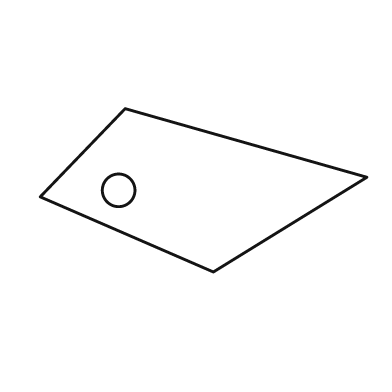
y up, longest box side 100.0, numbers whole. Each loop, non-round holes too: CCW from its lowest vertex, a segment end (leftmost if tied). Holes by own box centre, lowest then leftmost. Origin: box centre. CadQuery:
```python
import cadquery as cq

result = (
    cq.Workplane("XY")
    .moveTo(3.0, -25.0)
    .lineTo(50.0, 4.0)
    .lineTo(-24.0, 25.0)
    .lineTo(-50.0, -2.0)
    .close()
    .moveTo(-26.0, 0.0)
    .circle(5.0)
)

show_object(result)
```